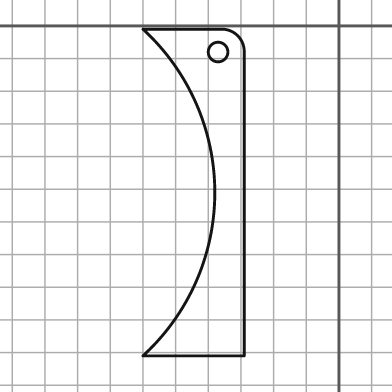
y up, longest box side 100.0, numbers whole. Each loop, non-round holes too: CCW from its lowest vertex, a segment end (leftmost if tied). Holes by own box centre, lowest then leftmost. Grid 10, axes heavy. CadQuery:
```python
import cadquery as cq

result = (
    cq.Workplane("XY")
    .moveTo(-60.0, -101.0)
    .lineTo(-29.0, -101.0)
    .lineTo(-29.0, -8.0)
    .threePointArc((-31.0, -3.0), (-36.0, -1.0))
    .lineTo(-60.0, -1.0)
    .threePointArc((-38.0, -51.0), (-60.0, -101.0))
    .close()
    .moveTo(-37.0, -8.0)
    .circle(3.0)
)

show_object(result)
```